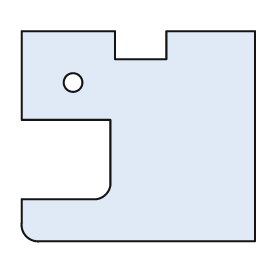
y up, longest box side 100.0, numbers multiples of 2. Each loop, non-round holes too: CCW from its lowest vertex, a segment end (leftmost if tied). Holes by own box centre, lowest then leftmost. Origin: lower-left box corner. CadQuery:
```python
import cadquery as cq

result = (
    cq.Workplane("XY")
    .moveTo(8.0, 0.0)
    .lineTo(100.0, 0.0)
    .lineTo(100.0, 90.0)
    .lineTo(62.0, 90.0)
    .lineTo(62.0, 78.0)
    .lineTo(40.0, 78.0)
    .lineTo(40.0, 90.0)
    .lineTo(0.0, 90.0)
    .lineTo(0.0, 52.0)
    .lineTo(38.0, 52.0)
    .lineTo(38.0, 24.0)
    .threePointArc((36.0, 20.0), (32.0, 18.0))
    .lineTo(0.0, 18.0)
    .lineTo(0.0, 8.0)
    .threePointArc((2.0, 2.0), (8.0, 0.0))
    .close()
    .moveTo(22.0, 68.0)
    .circle(4.0)
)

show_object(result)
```